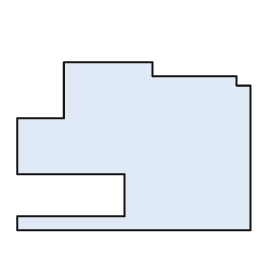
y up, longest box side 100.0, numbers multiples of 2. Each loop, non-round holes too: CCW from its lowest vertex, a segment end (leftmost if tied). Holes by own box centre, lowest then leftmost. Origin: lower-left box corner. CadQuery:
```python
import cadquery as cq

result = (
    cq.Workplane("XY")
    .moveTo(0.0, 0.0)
    .lineTo(100.0, 0.0)
    .lineTo(100.0, 62.0)
    .lineTo(94.0, 62.0)
    .lineTo(94.0, 66.0)
    .lineTo(58.0, 66.0)
    .lineTo(58.0, 72.0)
    .lineTo(20.0, 72.0)
    .lineTo(20.0, 48.0)
    .lineTo(0.0, 48.0)
    .lineTo(0.0, 24.0)
    .lineTo(46.0, 24.0)
    .lineTo(46.0, 6.0)
    .lineTo(0.0, 6.0)
    .close()
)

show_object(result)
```